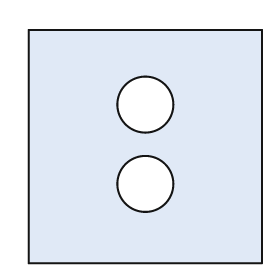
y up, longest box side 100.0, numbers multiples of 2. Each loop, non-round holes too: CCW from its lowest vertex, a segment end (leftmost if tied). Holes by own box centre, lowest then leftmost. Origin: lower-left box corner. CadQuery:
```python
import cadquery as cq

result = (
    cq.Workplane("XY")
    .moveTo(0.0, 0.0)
    .lineTo(100.0, 0.0)
    .lineTo(100.0, 100.0)
    .lineTo(0.0, 100.0)
    .close()
    .moveTo(50.0, 34.0)
    .circle(12.0)
    .moveTo(50.0, 68.0)
    .circle(12.0)
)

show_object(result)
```